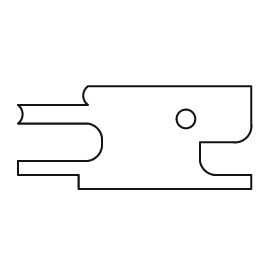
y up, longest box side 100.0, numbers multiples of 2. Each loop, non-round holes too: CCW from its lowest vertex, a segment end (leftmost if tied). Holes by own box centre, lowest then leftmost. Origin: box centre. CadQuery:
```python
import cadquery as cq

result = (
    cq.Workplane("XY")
    .moveTo(-24.0, -22.0)
    .lineTo(50.0, -22.0)
    .lineTo(50.0, -16.0)
    .lineTo(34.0, -16.0)
    .threePointArc((30.0, -14.0), (28.0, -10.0))
    .lineTo(28.0, -2.0)
    .lineTo(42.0, -2.0)
    .threePointArc((48.0, 0.0), (50.0, 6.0))
    .lineTo(50.0, 22.0)
    .lineTo(-20.0, 22.0)
    .threePointArc((-22.0, 18.0), (-20.0, 14.0))
    .lineTo(-50.0, 14.0)
    .threePointArc((-48.0, 10.0), (-50.0, 6.0))
    .lineTo(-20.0, 6.0)
    .threePointArc((-16.0, 4.0), (-14.0, 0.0))
    .lineTo(-14.0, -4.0)
    .threePointArc((-16.0, -8.0), (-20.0, -10.0))
    .lineTo(-50.0, -10.0)
    .lineTo(-50.0, -16.0)
    .lineTo(-24.0, -16.0)
    .close()
    .moveTo(22.0, 8.0)
    .circle(4.0)
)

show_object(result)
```